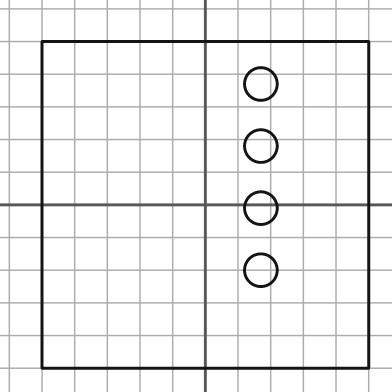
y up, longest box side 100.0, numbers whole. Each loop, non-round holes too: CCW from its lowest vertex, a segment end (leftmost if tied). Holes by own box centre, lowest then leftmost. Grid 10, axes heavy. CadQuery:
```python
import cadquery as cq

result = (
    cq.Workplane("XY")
    .moveTo(-50.0, -50.0)
    .lineTo(50.0, -50.0)
    .lineTo(50.0, 50.0)
    .lineTo(-50.0, 50.0)
    .close()
    .moveTo(17.0, -20.0)
    .circle(5.0)
    .moveTo(17.0, -1.0)
    .circle(5.0)
    .moveTo(17.0, 18.0)
    .circle(5.0)
    .moveTo(17.0, 37.0)
    .circle(5.0)
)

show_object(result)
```